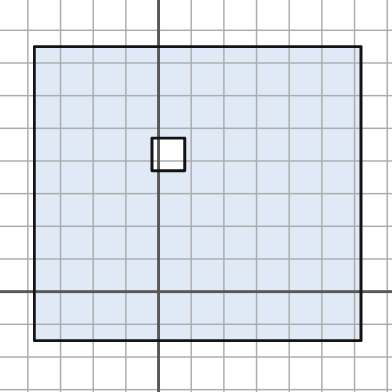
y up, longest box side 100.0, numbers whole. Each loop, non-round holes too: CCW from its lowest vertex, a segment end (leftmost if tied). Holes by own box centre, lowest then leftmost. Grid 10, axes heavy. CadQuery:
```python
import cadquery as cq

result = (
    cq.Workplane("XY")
    .moveTo(-38.0, -15.0)
    .lineTo(62.0, -15.0)
    .lineTo(62.0, 75.0)
    .lineTo(-38.0, 75.0)
    .close()
    .moveTo(-2.0, 37.0)
    .lineTo(8.0, 37.0)
    .lineTo(8.0, 47.0)
    .lineTo(-2.0, 47.0)
    .close()
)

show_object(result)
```